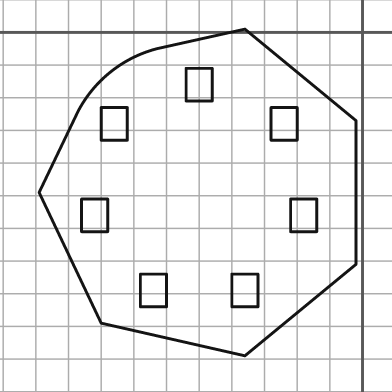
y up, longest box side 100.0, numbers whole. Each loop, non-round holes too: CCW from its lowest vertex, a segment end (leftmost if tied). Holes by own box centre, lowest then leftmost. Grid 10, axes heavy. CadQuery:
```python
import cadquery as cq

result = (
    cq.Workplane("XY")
    .moveTo(-36.0, -99.0)
    .lineTo(-2.0, -71.0)
    .lineTo(-2.0, -27.0)
    .lineTo(-36.0, 1.0)
    .lineTo(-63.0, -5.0)
    .threePointArc((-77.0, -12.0), (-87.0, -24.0))
    .lineTo(-99.0, -49.0)
    .lineTo(-80.0, -89.0)
    .close()
    .moveTo(-68.0, -84.0)
    .lineTo(-60.0, -84.0)
    .lineTo(-60.0, -74.0)
    .lineTo(-68.0, -74.0)
    .close()
    .moveTo(-40.0, -84.0)
    .lineTo(-32.0, -84.0)
    .lineTo(-32.0, -74.0)
    .lineTo(-40.0, -74.0)
    .close()
    .moveTo(-86.0, -61.0)
    .lineTo(-78.0, -61.0)
    .lineTo(-78.0, -51.0)
    .lineTo(-86.0, -51.0)
    .close()
    .moveTo(-22.0, -61.0)
    .lineTo(-14.0, -61.0)
    .lineTo(-14.0, -51.0)
    .lineTo(-22.0, -51.0)
    .close()
    .moveTo(-80.0, -33.0)
    .lineTo(-72.0, -33.0)
    .lineTo(-72.0, -23.0)
    .lineTo(-80.0, -23.0)
    .close()
    .moveTo(-28.0, -33.0)
    .lineTo(-20.0, -33.0)
    .lineTo(-20.0, -23.0)
    .lineTo(-28.0, -23.0)
    .close()
    .moveTo(-54.0, -21.0)
    .lineTo(-46.0, -21.0)
    .lineTo(-46.0, -11.0)
    .lineTo(-54.0, -11.0)
    .close()
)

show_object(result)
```